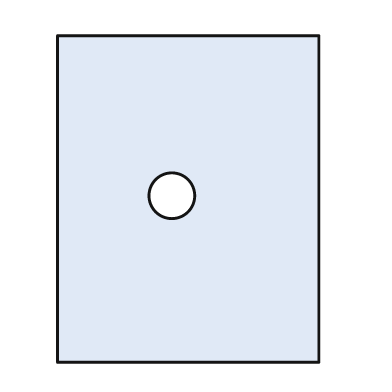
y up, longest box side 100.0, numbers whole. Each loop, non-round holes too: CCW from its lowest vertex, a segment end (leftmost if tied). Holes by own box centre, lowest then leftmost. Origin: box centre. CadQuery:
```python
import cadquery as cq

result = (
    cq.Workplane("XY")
    .moveTo(-40.0, -50.0)
    .lineTo(40.0, -50.0)
    .lineTo(40.0, 50.0)
    .lineTo(-40.0, 50.0)
    .close()
    .moveTo(-5.0, 1.0)
    .circle(7.0)
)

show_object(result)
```